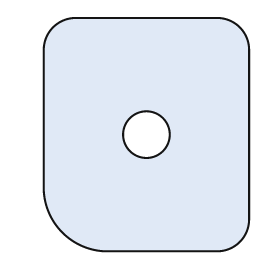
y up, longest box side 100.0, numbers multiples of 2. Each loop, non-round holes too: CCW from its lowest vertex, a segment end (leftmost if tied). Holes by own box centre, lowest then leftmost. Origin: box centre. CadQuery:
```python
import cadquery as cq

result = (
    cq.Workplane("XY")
    .moveTo(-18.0, -50.0)
    .lineTo(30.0, -50.0)
    .threePointArc((40.0, -46.0), (44.0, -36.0))
    .lineTo(44.0, 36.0)
    .threePointArc((40.0, 46.0), (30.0, 50.0))
    .lineTo(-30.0, 50.0)
    .threePointArc((-40.0, 46.0), (-44.0, 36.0))
    .lineTo(-44.0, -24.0)
    .threePointArc((-36.0, -42.0), (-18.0, -50.0))
    .close()
    .moveTo(0.0, 0.0)
    .circle(10.0)
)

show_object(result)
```